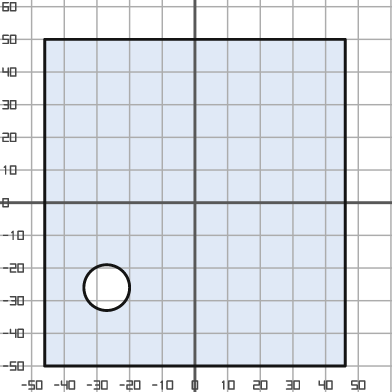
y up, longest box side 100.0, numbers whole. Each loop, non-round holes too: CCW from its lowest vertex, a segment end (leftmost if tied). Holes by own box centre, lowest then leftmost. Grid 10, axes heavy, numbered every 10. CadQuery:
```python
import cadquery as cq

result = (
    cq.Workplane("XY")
    .moveTo(-46.0, -50.0)
    .lineTo(46.0, -50.0)
    .lineTo(46.0, 50.0)
    .lineTo(-46.0, 50.0)
    .close()
    .moveTo(-27.0, -26.0)
    .circle(7.0)
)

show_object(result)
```